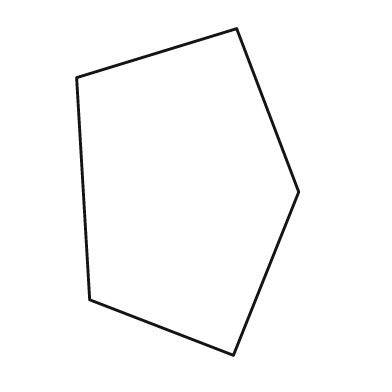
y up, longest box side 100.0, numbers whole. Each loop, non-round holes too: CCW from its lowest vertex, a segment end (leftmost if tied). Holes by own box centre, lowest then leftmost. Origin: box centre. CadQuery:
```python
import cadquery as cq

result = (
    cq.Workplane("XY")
    .moveTo(14.0, -50.0)
    .lineTo(34.0, 0.0)
    .lineTo(15.0, 50.0)
    .lineTo(-34.0, 35.0)
    .lineTo(-30.0, -33.0)
    .close()
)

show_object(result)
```